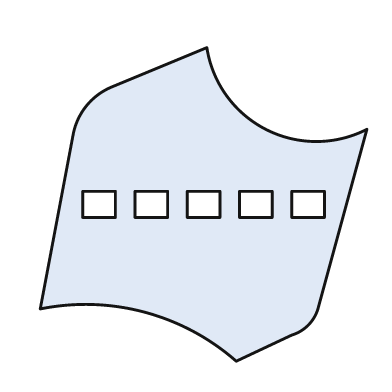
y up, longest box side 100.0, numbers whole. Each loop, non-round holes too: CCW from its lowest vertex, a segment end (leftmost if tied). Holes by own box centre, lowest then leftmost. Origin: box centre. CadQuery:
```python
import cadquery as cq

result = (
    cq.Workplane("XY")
    .moveTo(10.0, -48.0)
    .lineTo(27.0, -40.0)
    .threePointArc((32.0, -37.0), (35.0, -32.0))
    .lineTo(50.0, 23.0)
    .threePointArc((19.0, 23.0), (1.0, 48.0))
    .lineTo(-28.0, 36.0)
    .threePointArc((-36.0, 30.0), (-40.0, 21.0))
    .lineTo(-50.0, -32.0)
    .threePointArc((-18.0, -33.0), (10.0, -48.0))
    .close()
    .moveTo(-37.0, -4.0)
    .lineTo(-27.0, -4.0)
    .lineTo(-27.0, 4.0)
    .lineTo(-37.0, 4.0)
    .close()
    .moveTo(-21.0, -4.0)
    .lineTo(-11.0, -4.0)
    .lineTo(-11.0, 4.0)
    .lineTo(-21.0, 4.0)
    .close()
    .moveTo(-5.0, -4.0)
    .lineTo(5.0, -4.0)
    .lineTo(5.0, 4.0)
    .lineTo(-5.0, 4.0)
    .close()
    .moveTo(11.0, -4.0)
    .lineTo(21.0, -4.0)
    .lineTo(21.0, 4.0)
    .lineTo(11.0, 4.0)
    .close()
    .moveTo(27.0, -4.0)
    .lineTo(37.0, -4.0)
    .lineTo(37.0, 4.0)
    .lineTo(27.0, 4.0)
    .close()
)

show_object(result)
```